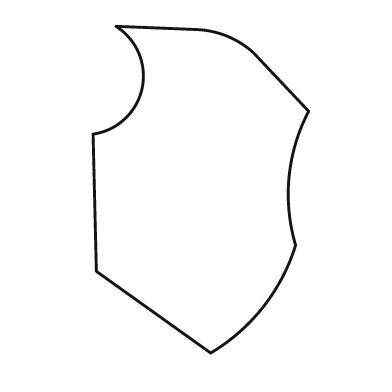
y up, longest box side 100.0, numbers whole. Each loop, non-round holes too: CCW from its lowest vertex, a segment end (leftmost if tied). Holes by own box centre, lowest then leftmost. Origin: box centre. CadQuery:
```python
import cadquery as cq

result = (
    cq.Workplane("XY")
    .moveTo(3.0, -50.0)
    .threePointArc((19.0, -36.0), (29.0, -17.0))
    .threePointArc((27.0, 4.0), (33.0, 24.0))
    .lineTo(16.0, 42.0)
    .threePointArc((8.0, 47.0), (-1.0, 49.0))
    .lineTo(-26.0, 50.0)
    .threePointArc((-18.0, 31.0), (-33.0, 17.0))
    .lineTo(-32.0, -25.0)
    .close()
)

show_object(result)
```